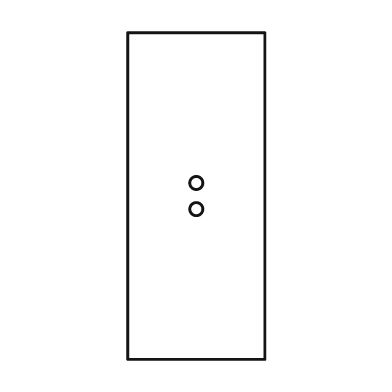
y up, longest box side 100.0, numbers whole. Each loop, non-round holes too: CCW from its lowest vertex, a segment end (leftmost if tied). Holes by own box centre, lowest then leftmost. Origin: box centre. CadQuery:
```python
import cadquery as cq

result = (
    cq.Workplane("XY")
    .moveTo(-21.0, -50.0)
    .lineTo(21.0, -50.0)
    .lineTo(21.0, 50.0)
    .lineTo(-21.0, 50.0)
    .close()
    .moveTo(0.0, -4.0)
    .circle(2.0)
    .moveTo(0.0, 4.0)
    .circle(2.0)
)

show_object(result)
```